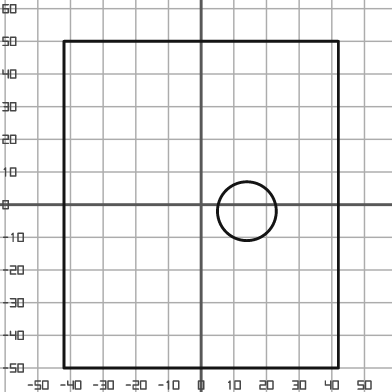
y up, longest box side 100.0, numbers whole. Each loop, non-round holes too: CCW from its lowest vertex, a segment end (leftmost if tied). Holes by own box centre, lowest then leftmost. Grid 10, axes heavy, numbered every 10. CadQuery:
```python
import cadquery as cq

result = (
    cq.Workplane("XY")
    .moveTo(-42.0, -50.0)
    .lineTo(42.0, -50.0)
    .lineTo(42.0, 50.0)
    .lineTo(-42.0, 50.0)
    .close()
    .moveTo(14.0, -2.0)
    .circle(9.0)
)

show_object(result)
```